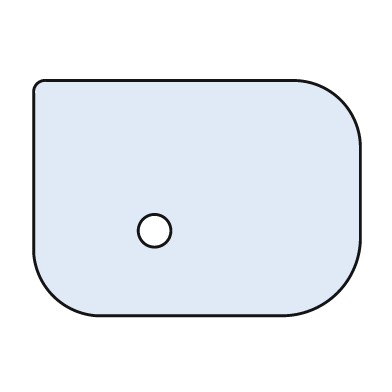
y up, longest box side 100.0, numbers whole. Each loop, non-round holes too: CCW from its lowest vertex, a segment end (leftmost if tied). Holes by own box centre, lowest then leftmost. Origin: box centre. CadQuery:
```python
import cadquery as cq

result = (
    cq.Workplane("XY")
    .moveTo(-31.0, -36.0)
    .lineTo(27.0, -36.0)
    .threePointArc((43.0, -29.0), (50.0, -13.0))
    .lineTo(50.0, 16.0)
    .threePointArc((44.0, 30.0), (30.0, 36.0))
    .lineTo(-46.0, 36.0)
    .threePointArc((-49.0, 35.0), (-50.0, 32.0))
    .lineTo(-50.0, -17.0)
    .threePointArc((-44.0, -30.0), (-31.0, -36.0))
    .close()
    .moveTo(-13.0, -10.0)
    .circle(5.0)
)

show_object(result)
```